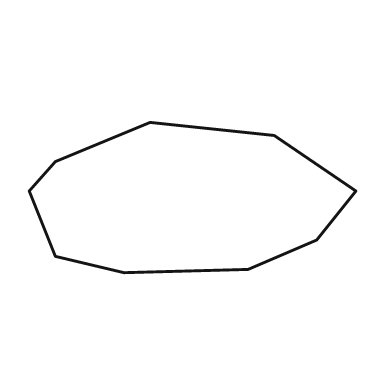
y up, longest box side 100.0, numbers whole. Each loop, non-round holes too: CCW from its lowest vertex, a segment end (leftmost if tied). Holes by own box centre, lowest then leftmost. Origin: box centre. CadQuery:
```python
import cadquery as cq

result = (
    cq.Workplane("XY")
    .moveTo(-21.0, -23.0)
    .lineTo(17.0, -22.0)
    .lineTo(38.0, -13.0)
    .lineTo(50.0, 2.0)
    .lineTo(25.0, 19.0)
    .lineTo(-13.0, 23.0)
    .lineTo(-42.0, 11.0)
    .lineTo(-50.0, 2.0)
    .lineTo(-42.0, -18.0)
    .close()
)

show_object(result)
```